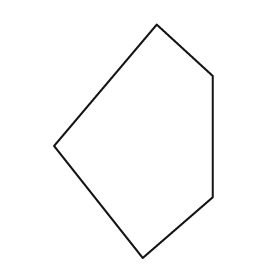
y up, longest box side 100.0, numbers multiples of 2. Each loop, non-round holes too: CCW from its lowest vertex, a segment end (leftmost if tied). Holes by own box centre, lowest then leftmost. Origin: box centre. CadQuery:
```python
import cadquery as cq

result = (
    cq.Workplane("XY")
    .moveTo(4.0, -50.0)
    .lineTo(34.0, -24.0)
    .lineTo(34.0, 28.0)
    .lineTo(10.0, 50.0)
    .lineTo(-34.0, -2.0)
    .close()
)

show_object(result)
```